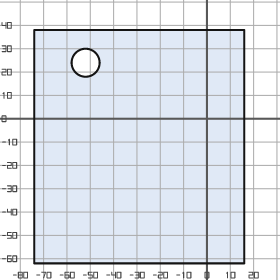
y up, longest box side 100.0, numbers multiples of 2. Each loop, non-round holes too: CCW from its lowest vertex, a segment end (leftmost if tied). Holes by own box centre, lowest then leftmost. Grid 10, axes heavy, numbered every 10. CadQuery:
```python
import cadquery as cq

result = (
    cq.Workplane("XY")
    .moveTo(-74.0, -62.0)
    .lineTo(16.0, -62.0)
    .lineTo(16.0, 38.0)
    .lineTo(-74.0, 38.0)
    .close()
    .moveTo(-52.0, 24.0)
    .circle(6.0)
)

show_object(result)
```